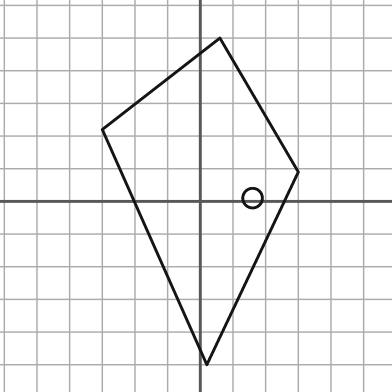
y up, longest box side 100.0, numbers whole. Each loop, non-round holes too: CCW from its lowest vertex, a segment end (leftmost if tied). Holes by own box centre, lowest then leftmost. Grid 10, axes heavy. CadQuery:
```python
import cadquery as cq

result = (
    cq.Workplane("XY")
    .moveTo(2.0, -50.0)
    .lineTo(30.0, 9.0)
    .lineTo(6.0, 50.0)
    .lineTo(-30.0, 22.0)
    .close()
    .moveTo(16.0, 1.0)
    .circle(3.0)
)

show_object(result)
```